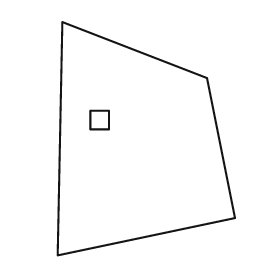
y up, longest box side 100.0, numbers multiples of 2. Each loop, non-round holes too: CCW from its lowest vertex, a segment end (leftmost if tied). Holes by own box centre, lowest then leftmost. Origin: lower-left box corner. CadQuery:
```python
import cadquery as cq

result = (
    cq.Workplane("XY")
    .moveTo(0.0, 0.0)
    .lineTo(76.0, 16.0)
    .lineTo(64.0, 76.0)
    .lineTo(2.0, 100.0)
    .close()
    .moveTo(14.0, 54.0)
    .lineTo(22.0, 54.0)
    .lineTo(22.0, 62.0)
    .lineTo(14.0, 62.0)
    .close()
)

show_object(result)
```